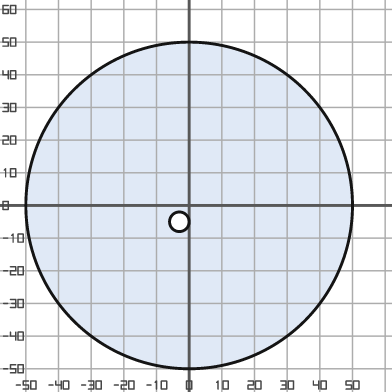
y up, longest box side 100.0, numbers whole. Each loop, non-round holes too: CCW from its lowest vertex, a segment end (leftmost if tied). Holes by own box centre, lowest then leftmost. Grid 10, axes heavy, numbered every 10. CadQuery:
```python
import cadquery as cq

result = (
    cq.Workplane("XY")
    .moveTo(0.0, 0.0)
    .circle(50.0)
    .moveTo(-3.0, -5.0)
    .circle(3.0)
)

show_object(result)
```